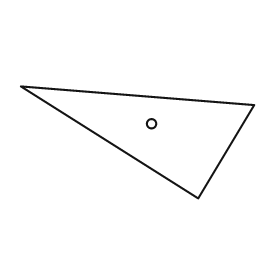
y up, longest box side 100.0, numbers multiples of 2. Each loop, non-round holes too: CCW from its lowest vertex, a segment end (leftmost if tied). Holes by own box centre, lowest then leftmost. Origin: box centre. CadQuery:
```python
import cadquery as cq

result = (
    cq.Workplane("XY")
    .moveTo(26.0, -24.0)
    .lineTo(50.0, 16.0)
    .lineTo(-50.0, 24.0)
    .close()
    .moveTo(6.0, 8.0)
    .circle(2.0)
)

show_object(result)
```